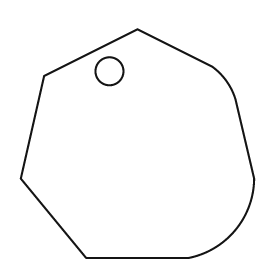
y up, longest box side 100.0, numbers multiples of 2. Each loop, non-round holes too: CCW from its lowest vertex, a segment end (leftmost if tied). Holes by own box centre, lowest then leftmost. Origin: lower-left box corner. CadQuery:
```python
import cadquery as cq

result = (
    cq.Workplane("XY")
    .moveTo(28.0, 0.0)
    .lineTo(72.0, 0.0)
    .threePointArc((92.0, 12.0), (100.0, 34.0))
    .lineTo(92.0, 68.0)
    .threePointArc((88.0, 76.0), (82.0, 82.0))
    .lineTo(50.0, 98.0)
    .lineTo(10.0, 78.0)
    .lineTo(0.0, 34.0)
    .close()
    .moveTo(38.0, 80.0)
    .circle(6.0)
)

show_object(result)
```